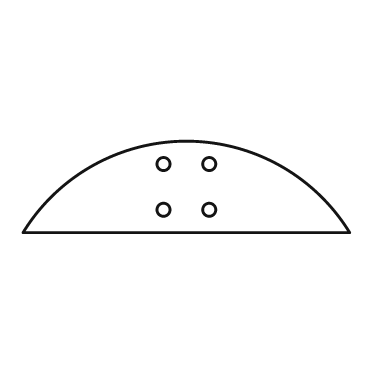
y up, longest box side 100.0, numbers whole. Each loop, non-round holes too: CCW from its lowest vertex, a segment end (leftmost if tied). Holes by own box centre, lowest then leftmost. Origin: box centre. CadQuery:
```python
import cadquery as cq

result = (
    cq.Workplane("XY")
    .moveTo(-50.0, -14.0)
    .lineTo(50.0, -14.0)
    .threePointArc((0.0, 14.0), (-50.0, -14.0))
    .close()
    .moveTo(-7.0, -7.0)
    .circle(2.0)
    .moveTo(7.0, -7.0)
    .circle(2.0)
    .moveTo(-7.0, 7.0)
    .circle(2.0)
    .moveTo(7.0, 7.0)
    .circle(2.0)
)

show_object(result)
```